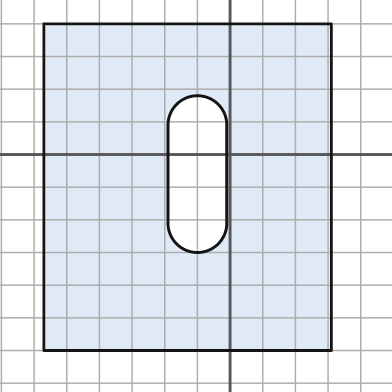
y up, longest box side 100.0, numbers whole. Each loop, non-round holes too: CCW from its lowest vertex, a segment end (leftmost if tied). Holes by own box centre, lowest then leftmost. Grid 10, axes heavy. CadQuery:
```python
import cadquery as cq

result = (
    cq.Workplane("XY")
    .moveTo(-57.0, -60.0)
    .lineTo(31.0, -60.0)
    .lineTo(31.0, 40.0)
    .lineTo(-57.0, 40.0)
    .close()
    .moveTo(-19.0, -21.0)
    .threePointArc((-10.0, -30.0), (-1.0, -21.0))
    .lineTo(-1.0, 9.0)
    .threePointArc((-10.0, 18.0), (-19.0, 9.0))
    .close()
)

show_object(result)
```